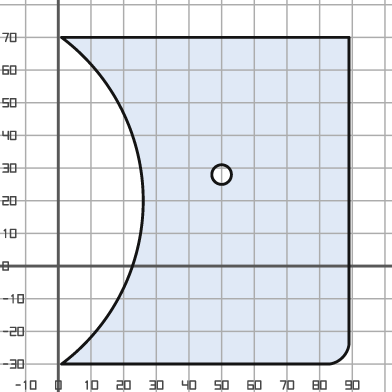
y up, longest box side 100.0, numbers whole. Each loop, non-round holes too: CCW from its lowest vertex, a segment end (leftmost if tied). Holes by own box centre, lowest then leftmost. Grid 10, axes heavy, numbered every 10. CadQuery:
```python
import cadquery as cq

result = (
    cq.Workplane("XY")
    .moveTo(1.0, -30.0)
    .lineTo(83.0, -30.0)
    .threePointArc((87.0, -28.0), (89.0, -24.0))
    .lineTo(89.0, 70.0)
    .lineTo(1.0, 70.0)
    .threePointArc((26.0, 20.0), (1.0, -30.0))
    .close()
    .moveTo(50.0, 28.0)
    .circle(3.0)
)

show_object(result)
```